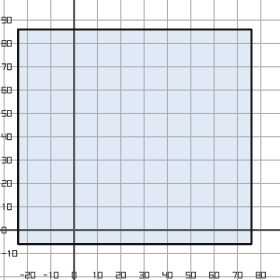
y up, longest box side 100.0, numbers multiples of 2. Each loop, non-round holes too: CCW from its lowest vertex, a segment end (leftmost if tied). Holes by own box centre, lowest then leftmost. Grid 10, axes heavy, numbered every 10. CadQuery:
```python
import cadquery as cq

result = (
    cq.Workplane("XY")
    .moveTo(-24.0, -6.0)
    .lineTo(76.0, -6.0)
    .lineTo(76.0, 86.0)
    .lineTo(-24.0, 86.0)
    .close()
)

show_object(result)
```